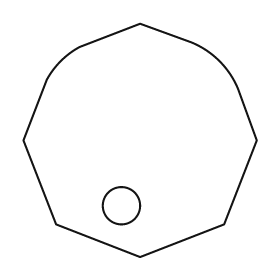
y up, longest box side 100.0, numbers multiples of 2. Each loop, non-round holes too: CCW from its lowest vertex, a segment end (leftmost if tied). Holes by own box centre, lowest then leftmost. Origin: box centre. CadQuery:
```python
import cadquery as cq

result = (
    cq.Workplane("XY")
    .moveTo(0.0, -50.0)
    .lineTo(36.0, -36.0)
    .lineTo(50.0, 0.0)
    .lineTo(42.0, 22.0)
    .threePointArc((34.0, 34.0), (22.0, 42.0))
    .lineTo(0.0, 50.0)
    .lineTo(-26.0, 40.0)
    .threePointArc((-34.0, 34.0), (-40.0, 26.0))
    .lineTo(-50.0, 0.0)
    .lineTo(-36.0, -36.0)
    .close()
    .moveTo(-8.0, -28.0)
    .circle(8.0)
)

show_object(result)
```